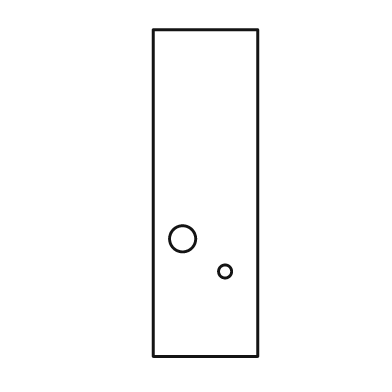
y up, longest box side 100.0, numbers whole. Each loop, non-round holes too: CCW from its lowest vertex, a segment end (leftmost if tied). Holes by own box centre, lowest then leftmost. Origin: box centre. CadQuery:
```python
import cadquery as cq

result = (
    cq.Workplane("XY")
    .moveTo(-16.0, -50.0)
    .lineTo(16.0, -50.0)
    .lineTo(16.0, 50.0)
    .lineTo(-16.0, 50.0)
    .close()
    .moveTo(6.0, -24.0)
    .circle(2.0)
    .moveTo(-7.0, -14.0)
    .circle(4.0)
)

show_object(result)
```